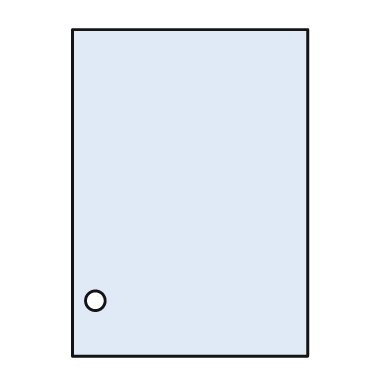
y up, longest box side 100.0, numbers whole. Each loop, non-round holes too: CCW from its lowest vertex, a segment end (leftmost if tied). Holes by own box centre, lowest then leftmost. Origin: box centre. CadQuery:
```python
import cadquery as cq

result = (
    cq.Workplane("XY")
    .moveTo(-36.0, -50.0)
    .lineTo(36.0, -50.0)
    .lineTo(36.0, 50.0)
    .lineTo(-36.0, 50.0)
    .close()
    .moveTo(-29.0, -33.0)
    .circle(3.0)
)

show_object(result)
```